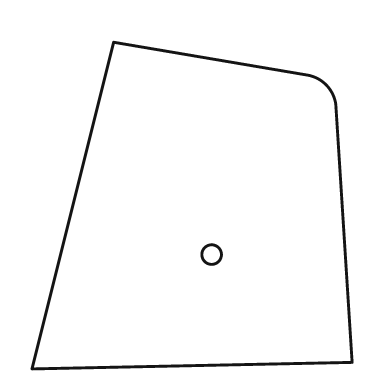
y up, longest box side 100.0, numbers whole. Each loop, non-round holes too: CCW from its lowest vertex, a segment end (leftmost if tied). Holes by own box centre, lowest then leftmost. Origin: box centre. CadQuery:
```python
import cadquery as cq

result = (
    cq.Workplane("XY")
    .moveTo(-49.0, -50.0)
    .lineTo(49.0, -48.0)
    .lineTo(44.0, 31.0)
    .threePointArc((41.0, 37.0), (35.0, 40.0))
    .lineTo(-24.0, 50.0)
    .close()
    .moveTo(6.0, -15.0)
    .circle(3.0)
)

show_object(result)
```